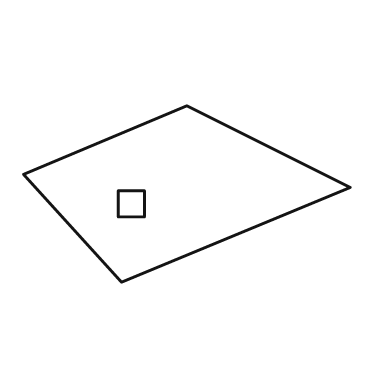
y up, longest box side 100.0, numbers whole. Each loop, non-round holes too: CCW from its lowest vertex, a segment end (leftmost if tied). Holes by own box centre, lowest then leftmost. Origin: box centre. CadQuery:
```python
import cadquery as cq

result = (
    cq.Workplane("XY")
    .moveTo(-20.0, -27.0)
    .lineTo(50.0, 2.0)
    .lineTo(0.0, 27.0)
    .lineTo(-50.0, 6.0)
    .close()
    .moveTo(-21.0, -7.0)
    .lineTo(-13.0, -7.0)
    .lineTo(-13.0, 1.0)
    .lineTo(-21.0, 1.0)
    .close()
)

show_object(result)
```